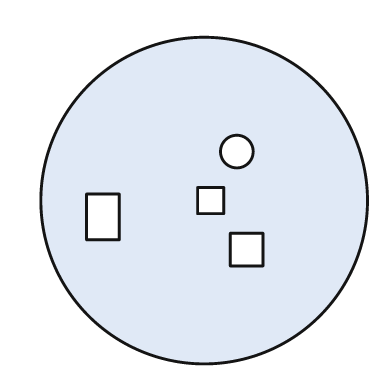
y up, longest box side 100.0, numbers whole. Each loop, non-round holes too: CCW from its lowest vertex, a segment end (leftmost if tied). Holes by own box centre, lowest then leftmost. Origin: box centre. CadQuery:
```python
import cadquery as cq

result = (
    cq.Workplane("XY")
    .moveTo(0.0, 0.0)
    .circle(50.0)
    .moveTo(8.0, -20.0)
    .lineTo(18.0, -20.0)
    .lineTo(18.0, -10.0)
    .lineTo(8.0, -10.0)
    .close()
    .moveTo(-36.0, -12.0)
    .lineTo(-26.0, -12.0)
    .lineTo(-26.0, 2.0)
    .lineTo(-36.0, 2.0)
    .close()
    .moveTo(-2.0, -4.0)
    .lineTo(6.0, -4.0)
    .lineTo(6.0, 4.0)
    .lineTo(-2.0, 4.0)
    .close()
    .moveTo(10.0, 15.0)
    .circle(5.0)
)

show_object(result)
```